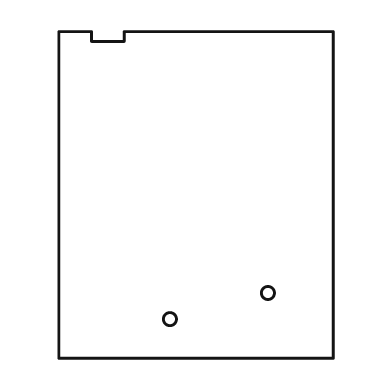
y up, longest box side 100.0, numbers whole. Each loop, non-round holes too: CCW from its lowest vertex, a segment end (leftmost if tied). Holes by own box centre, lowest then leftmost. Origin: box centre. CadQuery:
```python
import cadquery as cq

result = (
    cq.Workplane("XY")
    .moveTo(-42.0, -50.0)
    .lineTo(42.0, -50.0)
    .lineTo(42.0, 50.0)
    .lineTo(-22.0, 50.0)
    .lineTo(-22.0, 47.0)
    .lineTo(-32.0, 47.0)
    .lineTo(-32.0, 50.0)
    .lineTo(-42.0, 50.0)
    .close()
    .moveTo(-8.0, -38.0)
    .circle(2.0)
    .moveTo(22.0, -30.0)
    .circle(2.0)
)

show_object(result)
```